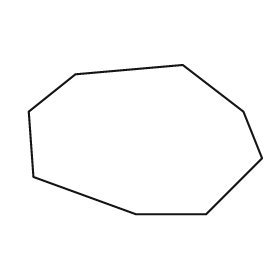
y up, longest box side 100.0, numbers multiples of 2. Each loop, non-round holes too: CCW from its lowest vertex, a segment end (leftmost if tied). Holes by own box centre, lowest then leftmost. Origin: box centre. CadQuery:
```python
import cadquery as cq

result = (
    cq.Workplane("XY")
    .moveTo(-4.0, -32.0)
    .lineTo(26.0, -32.0)
    .lineTo(50.0, -8.0)
    .lineTo(42.0, 12.0)
    .lineTo(16.0, 32.0)
    .lineTo(-30.0, 28.0)
    .lineTo(-50.0, 12.0)
    .lineTo(-48.0, -16.0)
    .close()
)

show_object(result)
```